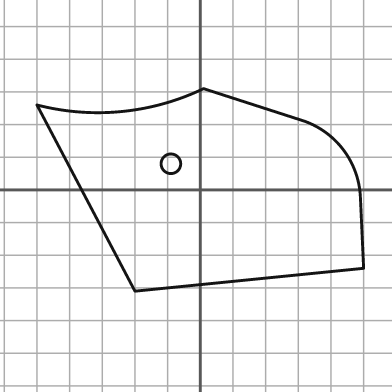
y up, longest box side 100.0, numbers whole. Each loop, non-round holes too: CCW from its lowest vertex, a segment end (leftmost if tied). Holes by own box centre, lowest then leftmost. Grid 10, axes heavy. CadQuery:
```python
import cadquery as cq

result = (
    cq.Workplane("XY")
    .moveTo(-20.0, -31.0)
    .lineTo(50.0, -24.0)
    .lineTo(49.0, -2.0)
    .threePointArc((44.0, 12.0), (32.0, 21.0))
    .lineTo(1.0, 31.0)
    .threePointArc((-24.0, 24.0), (-50.0, 26.0))
    .close()
    .moveTo(-9.0, 8.0)
    .circle(3.0)
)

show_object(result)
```